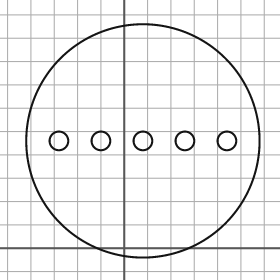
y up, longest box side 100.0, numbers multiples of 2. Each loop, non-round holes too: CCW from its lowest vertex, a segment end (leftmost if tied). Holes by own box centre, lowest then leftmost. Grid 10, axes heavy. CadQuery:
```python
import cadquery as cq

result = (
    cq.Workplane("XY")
    .moveTo(8.0, 46.0)
    .circle(50.0)
    .moveTo(-28.0, 46.0)
    .circle(4.0)
    .moveTo(-10.0, 46.0)
    .circle(4.0)
    .moveTo(8.0, 46.0)
    .circle(4.0)
    .moveTo(26.0, 46.0)
    .circle(4.0)
    .moveTo(44.0, 46.0)
    .circle(4.0)
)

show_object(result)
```